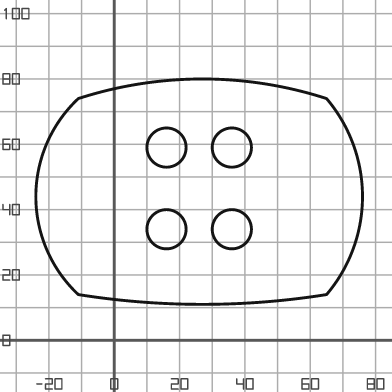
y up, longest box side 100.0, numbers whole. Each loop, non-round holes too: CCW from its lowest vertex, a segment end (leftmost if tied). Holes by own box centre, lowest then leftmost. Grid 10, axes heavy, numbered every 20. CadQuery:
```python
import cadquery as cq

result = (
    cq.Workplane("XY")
    .moveTo(-11.0, 14.0)
    .threePointArc((27.0, 11.0), (65.0, 14.0))
    .threePointArc((76.0, 44.0), (65.0, 74.0))
    .threePointArc((27.0, 80.0), (-11.0, 74.0))
    .threePointArc((-24.0, 44.0), (-11.0, 14.0))
    .close()
    .moveTo(16.0, 34.0)
    .circle(6.0)
    .moveTo(36.0, 34.0)
    .circle(6.0)
    .moveTo(16.0, 59.0)
    .circle(6.0)
    .moveTo(36.0, 59.0)
    .circle(6.0)
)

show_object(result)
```